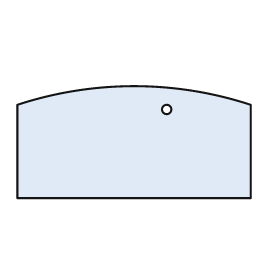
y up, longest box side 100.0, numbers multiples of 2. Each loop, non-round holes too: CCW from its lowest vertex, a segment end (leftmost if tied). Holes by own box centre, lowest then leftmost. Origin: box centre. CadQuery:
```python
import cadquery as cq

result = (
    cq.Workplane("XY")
    .moveTo(-50.0, -24.0)
    .lineTo(50.0, -24.0)
    .lineTo(50.0, 16.0)
    .threePointArc((0.0, 24.0), (-50.0, 16.0))
    .close()
    .moveTo(14.0, 14.0)
    .circle(2.0)
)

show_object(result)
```